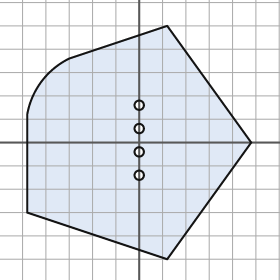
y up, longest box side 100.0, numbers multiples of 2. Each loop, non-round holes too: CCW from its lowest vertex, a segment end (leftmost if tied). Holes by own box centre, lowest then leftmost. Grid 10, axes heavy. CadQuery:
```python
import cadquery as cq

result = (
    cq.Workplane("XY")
    .moveTo(12.0, -50.0)
    .lineTo(48.0, 0.0)
    .lineTo(12.0, 50.0)
    .lineTo(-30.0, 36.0)
    .threePointArc((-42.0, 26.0), (-48.0, 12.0))
    .lineTo(-48.0, -30.0)
    .close()
    .moveTo(0.0, -14.0)
    .circle(2.0)
    .moveTo(0.0, -4.0)
    .circle(2.0)
    .moveTo(0.0, 6.0)
    .circle(2.0)
    .moveTo(0.0, 16.0)
    .circle(2.0)
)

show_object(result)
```